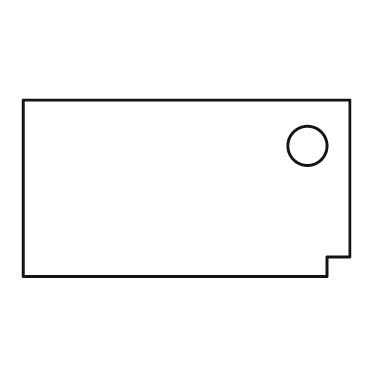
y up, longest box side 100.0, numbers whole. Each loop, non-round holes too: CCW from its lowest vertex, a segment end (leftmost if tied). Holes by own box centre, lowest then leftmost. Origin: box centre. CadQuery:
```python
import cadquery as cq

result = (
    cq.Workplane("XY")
    .moveTo(-50.0, -27.0)
    .lineTo(43.0, -27.0)
    .lineTo(43.0, -21.0)
    .lineTo(50.0, -21.0)
    .lineTo(50.0, 27.0)
    .lineTo(-50.0, 27.0)
    .close()
    .moveTo(37.0, 13.0)
    .circle(6.0)
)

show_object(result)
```